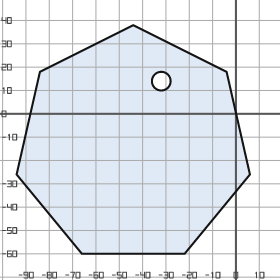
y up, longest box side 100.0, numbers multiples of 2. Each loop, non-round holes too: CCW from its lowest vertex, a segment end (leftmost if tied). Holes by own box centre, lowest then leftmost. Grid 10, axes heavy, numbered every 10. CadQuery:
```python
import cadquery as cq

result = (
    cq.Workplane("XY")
    .moveTo(-66.0, -60.0)
    .lineTo(-22.0, -60.0)
    .lineTo(6.0, -26.0)
    .lineTo(-4.0, 18.0)
    .lineTo(-44.0, 38.0)
    .lineTo(-84.0, 18.0)
    .lineTo(-94.0, -26.0)
    .close()
    .moveTo(-32.0, 14.0)
    .circle(4.0)
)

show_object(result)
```